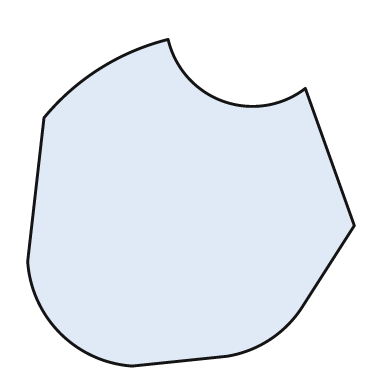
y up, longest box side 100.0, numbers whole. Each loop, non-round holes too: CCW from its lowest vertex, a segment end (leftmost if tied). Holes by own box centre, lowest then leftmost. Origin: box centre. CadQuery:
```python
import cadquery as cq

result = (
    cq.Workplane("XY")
    .moveTo(-18.0, -50.0)
    .lineTo(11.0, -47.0)
    .threePointArc((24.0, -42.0), (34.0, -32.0))
    .lineTo(50.0, -7.0)
    .lineTo(35.0, 35.0)
    .threePointArc((10.0, 31.0), (-7.0, 50.0))
    .threePointArc((-28.0, 41.0), (-45.0, 26.0))
    .lineTo(-50.0, -18.0)
    .threePointArc((-40.0, -40.0), (-18.0, -50.0))
    .close()
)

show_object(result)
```